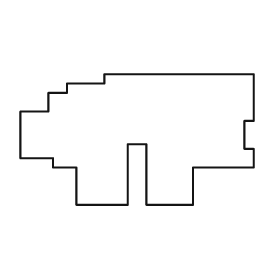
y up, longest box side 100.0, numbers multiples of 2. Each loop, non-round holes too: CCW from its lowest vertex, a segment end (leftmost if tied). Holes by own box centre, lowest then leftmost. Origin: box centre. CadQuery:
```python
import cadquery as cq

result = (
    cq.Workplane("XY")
    .moveTo(-26.0, -28.0)
    .lineTo(-4.0, -28.0)
    .lineTo(-4.0, -2.0)
    .lineTo(4.0, -2.0)
    .lineTo(4.0, -28.0)
    .lineTo(24.0, -28.0)
    .lineTo(24.0, -12.0)
    .lineTo(50.0, -12.0)
    .lineTo(50.0, -4.0)
    .lineTo(46.0, -4.0)
    .lineTo(46.0, 8.0)
    .lineTo(50.0, 8.0)
    .lineTo(50.0, 28.0)
    .lineTo(-14.0, 28.0)
    .lineTo(-14.0, 24.0)
    .lineTo(-30.0, 24.0)
    .lineTo(-30.0, 20.0)
    .lineTo(-38.0, 20.0)
    .lineTo(-38.0, 12.0)
    .lineTo(-50.0, 12.0)
    .lineTo(-50.0, -8.0)
    .lineTo(-36.0, -8.0)
    .lineTo(-36.0, -12.0)
    .lineTo(-26.0, -12.0)
    .close()
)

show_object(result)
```